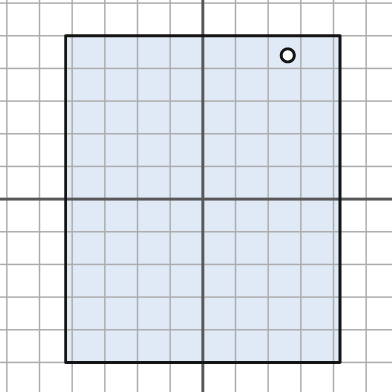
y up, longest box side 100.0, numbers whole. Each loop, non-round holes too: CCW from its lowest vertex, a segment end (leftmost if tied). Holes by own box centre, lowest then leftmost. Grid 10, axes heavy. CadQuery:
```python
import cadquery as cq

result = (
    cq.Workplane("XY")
    .moveTo(-42.0, -50.0)
    .lineTo(42.0, -50.0)
    .lineTo(42.0, 50.0)
    .lineTo(-42.0, 50.0)
    .close()
    .moveTo(26.0, 44.0)
    .circle(2.0)
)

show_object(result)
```